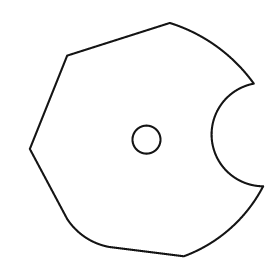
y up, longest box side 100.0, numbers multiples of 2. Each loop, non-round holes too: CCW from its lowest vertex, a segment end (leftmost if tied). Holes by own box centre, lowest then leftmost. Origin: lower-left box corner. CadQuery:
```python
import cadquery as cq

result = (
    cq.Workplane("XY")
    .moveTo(66.0, 0.0)
    .threePointArc((86.0, 12.0), (100.0, 30.0))
    .threePointArc((78.0, 50.0), (96.0, 74.0))
    .threePointArc((80.0, 90.0), (60.0, 100.0))
    .lineTo(16.0, 86.0)
    .lineTo(0.0, 46.0)
    .lineTo(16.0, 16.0)
    .threePointArc((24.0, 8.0), (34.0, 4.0))
    .close()
    .moveTo(50.0, 50.0)
    .circle(6.0)
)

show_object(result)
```